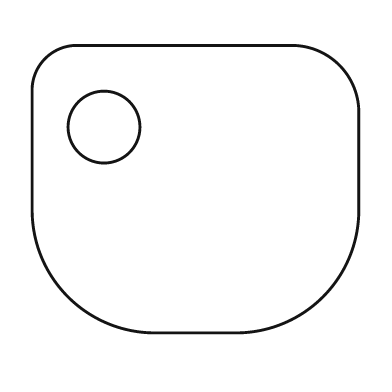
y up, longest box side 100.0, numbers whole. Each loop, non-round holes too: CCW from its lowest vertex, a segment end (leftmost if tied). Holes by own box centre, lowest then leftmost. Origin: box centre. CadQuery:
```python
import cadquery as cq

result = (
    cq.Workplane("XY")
    .moveTo(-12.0, -44.0)
    .lineTo(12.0, -44.0)
    .threePointArc((39.0, -33.0), (50.0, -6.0))
    .lineTo(50.0, 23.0)
    .threePointArc((44.0, 38.0), (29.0, 44.0))
    .lineTo(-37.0, 44.0)
    .threePointArc((-46.0, 40.0), (-50.0, 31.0))
    .lineTo(-50.0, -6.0)
    .threePointArc((-39.0, -33.0), (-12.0, -44.0))
    .close()
    .moveTo(-28.0, 19.0)
    .circle(11.0)
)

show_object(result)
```